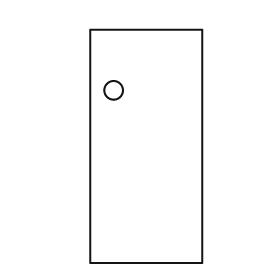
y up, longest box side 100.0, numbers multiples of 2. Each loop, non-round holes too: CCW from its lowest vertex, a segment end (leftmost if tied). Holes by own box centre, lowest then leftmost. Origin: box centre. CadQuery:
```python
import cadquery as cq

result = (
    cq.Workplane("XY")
    .moveTo(-24.0, -50.0)
    .lineTo(24.0, -50.0)
    .lineTo(24.0, 50.0)
    .lineTo(-24.0, 50.0)
    .close()
    .moveTo(-14.0, 24.0)
    .circle(4.0)
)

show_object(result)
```